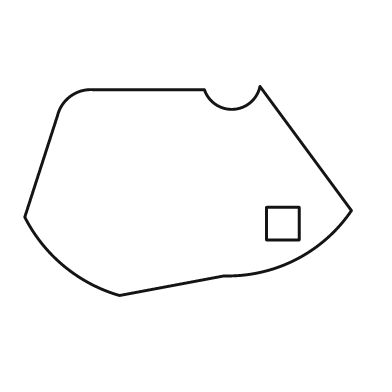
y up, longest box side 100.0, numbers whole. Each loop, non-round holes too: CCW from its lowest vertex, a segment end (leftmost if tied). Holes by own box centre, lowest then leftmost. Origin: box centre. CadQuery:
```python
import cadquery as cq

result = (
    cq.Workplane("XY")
    .moveTo(-21.0, -32.0)
    .lineTo(11.0, -26.0)
    .threePointArc((33.0, -21.0), (50.0, -6.0))
    .lineTo(22.0, 32.0)
    .threePointArc((14.0, 25.0), (5.0, 31.0))
    .lineTo(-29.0, 31.0)
    .threePointArc((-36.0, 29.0), (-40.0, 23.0))
    .lineTo(-50.0, -8.0)
    .threePointArc((-38.0, -23.0), (-21.0, -32.0))
    .close()
    .moveTo(24.0, -15.0)
    .lineTo(34.0, -15.0)
    .lineTo(34.0, -5.0)
    .lineTo(24.0, -5.0)
    .close()
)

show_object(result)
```